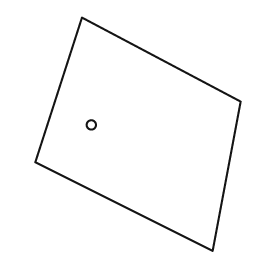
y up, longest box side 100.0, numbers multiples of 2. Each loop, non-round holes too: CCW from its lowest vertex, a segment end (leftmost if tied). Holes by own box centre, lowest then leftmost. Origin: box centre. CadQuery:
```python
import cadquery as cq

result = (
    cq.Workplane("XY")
    .moveTo(32.0, -50.0)
    .lineTo(44.0, 14.0)
    .lineTo(-24.0, 50.0)
    .lineTo(-44.0, -12.0)
    .close()
    .moveTo(-20.0, 4.0)
    .circle(2.0)
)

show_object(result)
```